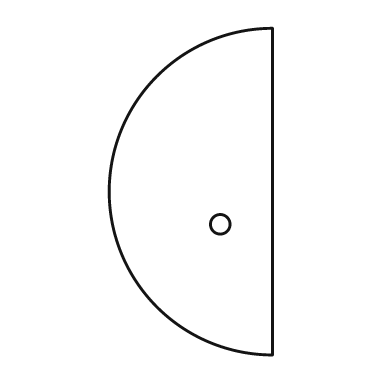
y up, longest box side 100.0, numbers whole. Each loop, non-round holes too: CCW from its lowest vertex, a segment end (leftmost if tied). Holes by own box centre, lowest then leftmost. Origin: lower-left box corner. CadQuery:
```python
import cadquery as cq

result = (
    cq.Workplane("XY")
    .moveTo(50.0, 0.0)
    .lineTo(50.0, 100.0)
    .threePointArc((0.0, 50.0), (50.0, 0.0))
    .close()
    .moveTo(34.0, 40.0)
    .circle(3.0)
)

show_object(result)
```